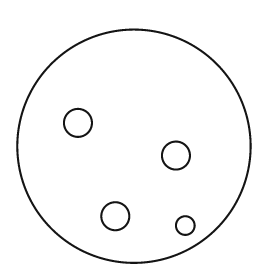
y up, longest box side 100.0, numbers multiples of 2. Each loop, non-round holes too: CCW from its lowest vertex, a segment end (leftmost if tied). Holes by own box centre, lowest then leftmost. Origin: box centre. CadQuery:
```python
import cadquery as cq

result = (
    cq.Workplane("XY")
    .moveTo(0.0, 0.0)
    .circle(50.0)
    .moveTo(22.0, -34.0)
    .circle(4.0)
    .moveTo(-8.0, -30.0)
    .circle(6.0)
    .moveTo(18.0, -4.0)
    .circle(6.0)
    .moveTo(-24.0, 10.0)
    .circle(6.0)
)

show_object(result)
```